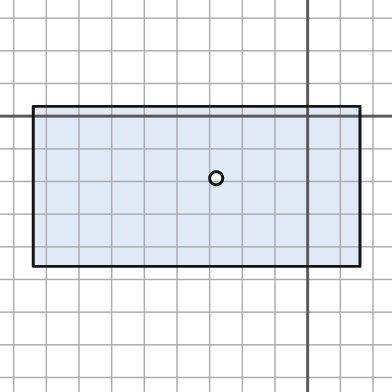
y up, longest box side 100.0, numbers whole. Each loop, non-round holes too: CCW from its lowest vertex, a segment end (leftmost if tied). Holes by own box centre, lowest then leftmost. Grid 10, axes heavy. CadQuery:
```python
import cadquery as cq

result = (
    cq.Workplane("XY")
    .moveTo(-84.0, -46.0)
    .lineTo(16.0, -46.0)
    .lineTo(16.0, 3.0)
    .lineTo(-84.0, 3.0)
    .close()
    .moveTo(-28.0, -19.0)
    .circle(2.0)
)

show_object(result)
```